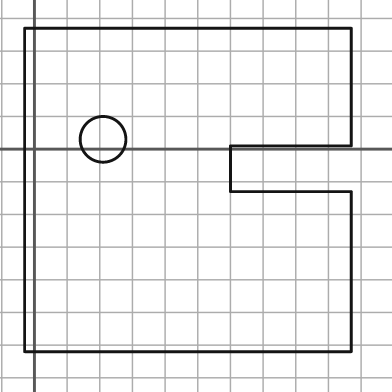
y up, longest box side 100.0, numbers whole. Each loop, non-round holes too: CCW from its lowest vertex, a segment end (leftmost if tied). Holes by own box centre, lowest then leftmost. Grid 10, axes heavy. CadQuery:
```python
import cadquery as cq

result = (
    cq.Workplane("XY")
    .moveTo(-3.0, -62.0)
    .lineTo(97.0, -62.0)
    .lineTo(97.0, -13.0)
    .lineTo(60.0, -13.0)
    .lineTo(60.0, 1.0)
    .lineTo(97.0, 1.0)
    .lineTo(97.0, 37.0)
    .lineTo(-3.0, 37.0)
    .close()
    .moveTo(21.0, 3.0)
    .circle(7.0)
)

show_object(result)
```